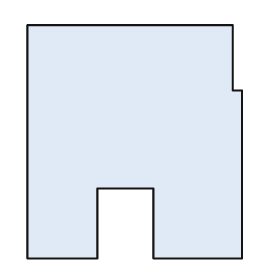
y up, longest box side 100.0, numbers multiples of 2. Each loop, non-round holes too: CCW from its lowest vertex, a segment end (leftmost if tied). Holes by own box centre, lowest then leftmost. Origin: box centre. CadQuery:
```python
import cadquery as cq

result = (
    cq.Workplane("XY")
    .moveTo(-46.0, -50.0)
    .lineTo(-16.0, -50.0)
    .lineTo(-16.0, -20.0)
    .lineTo(8.0, -20.0)
    .lineTo(8.0, -50.0)
    .lineTo(46.0, -50.0)
    .lineTo(46.0, 22.0)
    .lineTo(42.0, 22.0)
    .lineTo(42.0, 50.0)
    .lineTo(-46.0, 50.0)
    .close()
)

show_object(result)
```